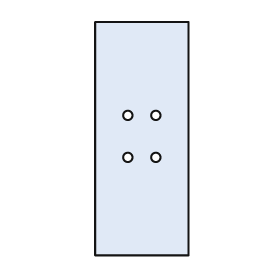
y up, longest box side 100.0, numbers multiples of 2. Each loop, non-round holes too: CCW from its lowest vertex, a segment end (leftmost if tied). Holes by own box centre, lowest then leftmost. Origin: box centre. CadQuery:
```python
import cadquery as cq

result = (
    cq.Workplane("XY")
    .moveTo(-20.0, -50.0)
    .lineTo(20.0, -50.0)
    .lineTo(20.0, 50.0)
    .lineTo(-20.0, 50.0)
    .close()
    .moveTo(-6.0, -8.0)
    .circle(2.0)
    .moveTo(6.0, -8.0)
    .circle(2.0)
    .moveTo(-6.0, 10.0)
    .circle(2.0)
    .moveTo(6.0, 10.0)
    .circle(2.0)
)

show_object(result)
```